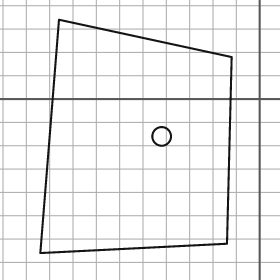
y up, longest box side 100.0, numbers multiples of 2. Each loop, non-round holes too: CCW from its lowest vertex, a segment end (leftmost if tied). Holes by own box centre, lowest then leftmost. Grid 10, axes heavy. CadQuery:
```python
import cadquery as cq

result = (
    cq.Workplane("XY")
    .moveTo(-94.0, -66.0)
    .lineTo(-14.0, -62.0)
    .lineTo(-12.0, 18.0)
    .lineTo(-86.0, 34.0)
    .close()
    .moveTo(-42.0, -16.0)
    .circle(4.0)
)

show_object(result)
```